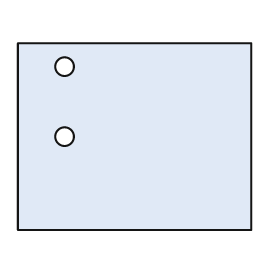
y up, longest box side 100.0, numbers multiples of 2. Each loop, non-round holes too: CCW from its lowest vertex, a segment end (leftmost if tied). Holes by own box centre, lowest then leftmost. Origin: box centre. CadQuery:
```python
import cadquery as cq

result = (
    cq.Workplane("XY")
    .moveTo(-50.0, -40.0)
    .lineTo(50.0, -40.0)
    .lineTo(50.0, 40.0)
    .lineTo(-50.0, 40.0)
    .close()
    .moveTo(-30.0, 0.0)
    .circle(4.0)
    .moveTo(-30.0, 30.0)
    .circle(4.0)
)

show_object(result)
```